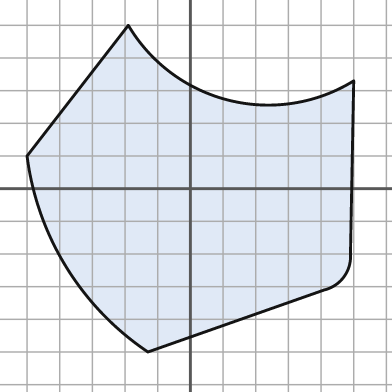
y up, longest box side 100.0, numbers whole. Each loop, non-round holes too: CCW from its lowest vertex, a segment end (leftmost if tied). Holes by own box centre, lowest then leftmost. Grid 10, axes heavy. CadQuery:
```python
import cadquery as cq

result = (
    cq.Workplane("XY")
    .moveTo(-13.0, -50.0)
    .lineTo(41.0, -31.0)
    .threePointArc((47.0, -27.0), (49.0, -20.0))
    .lineTo(50.0, 33.0)
    .threePointArc((12.0, 27.0), (-19.0, 50.0))
    .lineTo(-50.0, 10.0)
    .threePointArc((-38.0, -24.0), (-13.0, -50.0))
    .close()
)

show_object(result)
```